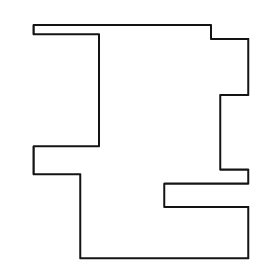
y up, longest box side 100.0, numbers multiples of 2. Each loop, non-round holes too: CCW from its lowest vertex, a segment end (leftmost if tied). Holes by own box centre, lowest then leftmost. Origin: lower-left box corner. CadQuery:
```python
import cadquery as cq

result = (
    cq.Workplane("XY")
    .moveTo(20.0, 0.0)
    .lineTo(92.0, 0.0)
    .lineTo(92.0, 22.0)
    .lineTo(56.0, 22.0)
    .lineTo(56.0, 32.0)
    .lineTo(92.0, 32.0)
    .lineTo(92.0, 38.0)
    .lineTo(80.0, 38.0)
    .lineTo(80.0, 70.0)
    .lineTo(92.0, 70.0)
    .lineTo(92.0, 94.0)
    .lineTo(76.0, 94.0)
    .lineTo(76.0, 100.0)
    .lineTo(0.0, 100.0)
    .lineTo(0.0, 96.0)
    .lineTo(28.0, 96.0)
    .lineTo(28.0, 48.0)
    .lineTo(0.0, 48.0)
    .lineTo(0.0, 36.0)
    .lineTo(20.0, 36.0)
    .close()
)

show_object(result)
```